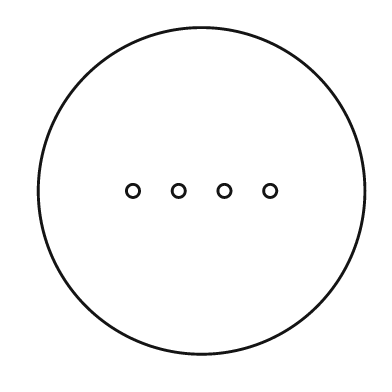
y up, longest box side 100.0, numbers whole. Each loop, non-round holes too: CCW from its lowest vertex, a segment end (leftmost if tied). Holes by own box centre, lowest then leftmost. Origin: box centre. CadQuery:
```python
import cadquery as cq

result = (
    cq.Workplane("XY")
    .moveTo(0.0, 0.0)
    .circle(50.0)
    .moveTo(-21.0, 0.0)
    .circle(2.0)
    .moveTo(-7.0, 0.0)
    .circle(2.0)
    .moveTo(7.0, 0.0)
    .circle(2.0)
    .moveTo(21.0, 0.0)
    .circle(2.0)
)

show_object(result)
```